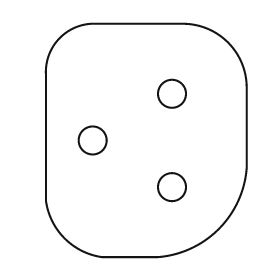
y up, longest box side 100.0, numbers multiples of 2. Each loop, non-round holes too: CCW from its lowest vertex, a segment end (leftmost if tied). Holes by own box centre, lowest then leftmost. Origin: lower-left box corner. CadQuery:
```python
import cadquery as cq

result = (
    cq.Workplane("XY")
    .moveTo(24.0, 0.0)
    .lineTo(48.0, 0.0)
    .threePointArc((74.0, 12.0), (86.0, 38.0))
    .lineTo(86.0, 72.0)
    .threePointArc((78.0, 92.0), (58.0, 100.0))
    .lineTo(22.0, 100.0)
    .threePointArc((6.0, 94.0), (0.0, 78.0))
    .lineTo(0.0, 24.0)
    .threePointArc((8.0, 8.0), (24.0, 0.0))
    .close()
    .moveTo(54.0, 30.0)
    .circle(6.0)
    .moveTo(20.0, 50.0)
    .circle(6.0)
    .moveTo(54.0, 70.0)
    .circle(6.0)
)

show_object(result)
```